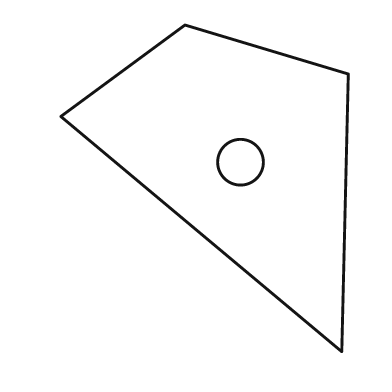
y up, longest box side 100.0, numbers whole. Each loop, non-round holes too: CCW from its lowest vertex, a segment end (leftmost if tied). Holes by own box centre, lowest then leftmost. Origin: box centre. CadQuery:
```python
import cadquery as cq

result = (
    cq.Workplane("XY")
    .moveTo(42.0, -50.0)
    .lineTo(44.0, 35.0)
    .lineTo(-6.0, 50.0)
    .lineTo(-44.0, 22.0)
    .close()
    .moveTo(11.0, 8.0)
    .circle(7.0)
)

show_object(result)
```